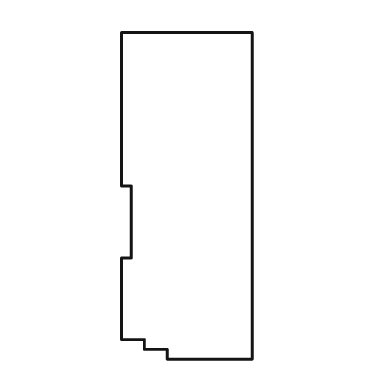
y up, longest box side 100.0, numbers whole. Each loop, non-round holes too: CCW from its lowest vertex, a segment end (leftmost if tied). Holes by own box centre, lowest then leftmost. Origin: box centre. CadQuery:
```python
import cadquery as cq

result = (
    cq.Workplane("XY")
    .moveTo(-6.0, -50.0)
    .lineTo(20.0, -50.0)
    .lineTo(20.0, 50.0)
    .lineTo(-20.0, 50.0)
    .lineTo(-20.0, 3.0)
    .lineTo(-17.0, 3.0)
    .lineTo(-17.0, -19.0)
    .lineTo(-20.0, -19.0)
    .lineTo(-20.0, -44.0)
    .lineTo(-13.0, -44.0)
    .lineTo(-13.0, -47.0)
    .lineTo(-6.0, -47.0)
    .close()
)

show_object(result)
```